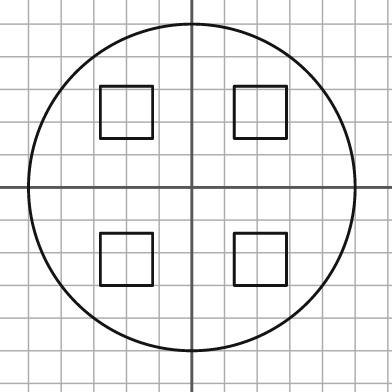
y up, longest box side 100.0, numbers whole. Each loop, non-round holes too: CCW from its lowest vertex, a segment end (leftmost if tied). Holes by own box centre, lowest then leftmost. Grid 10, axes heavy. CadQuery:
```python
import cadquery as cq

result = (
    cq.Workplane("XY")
    .moveTo(0.0, 0.0)
    .circle(50.0)
    .moveTo(-28.0, -30.0)
    .lineTo(-12.0, -30.0)
    .lineTo(-12.0, -14.0)
    .lineTo(-28.0, -14.0)
    .close()
    .moveTo(13.0, -30.0)
    .lineTo(29.0, -30.0)
    .lineTo(29.0, -14.0)
    .lineTo(13.0, -14.0)
    .close()
    .moveTo(-28.0, 15.0)
    .lineTo(-12.0, 15.0)
    .lineTo(-12.0, 31.0)
    .lineTo(-28.0, 31.0)
    .close()
    .moveTo(13.0, 15.0)
    .lineTo(29.0, 15.0)
    .lineTo(29.0, 31.0)
    .lineTo(13.0, 31.0)
    .close()
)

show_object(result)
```